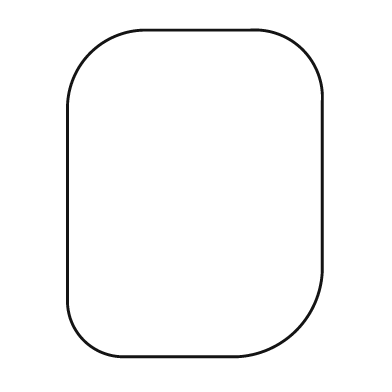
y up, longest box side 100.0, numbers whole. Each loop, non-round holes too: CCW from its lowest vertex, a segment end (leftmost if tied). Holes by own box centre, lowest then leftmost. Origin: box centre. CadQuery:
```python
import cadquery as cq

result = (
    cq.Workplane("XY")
    .moveTo(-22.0, -50.0)
    .lineTo(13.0, -50.0)
    .threePointArc((31.0, -42.0), (39.0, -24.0))
    .lineTo(39.0, 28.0)
    .threePointArc((33.0, 44.0), (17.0, 50.0))
    .lineTo(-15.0, 50.0)
    .threePointArc((-32.0, 43.0), (-39.0, 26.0))
    .lineTo(-39.0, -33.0)
    .threePointArc((-34.0, -45.0), (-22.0, -50.0))
    .close()
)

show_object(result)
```